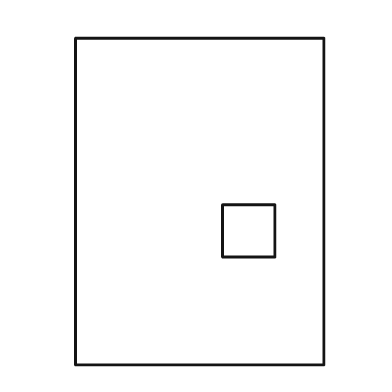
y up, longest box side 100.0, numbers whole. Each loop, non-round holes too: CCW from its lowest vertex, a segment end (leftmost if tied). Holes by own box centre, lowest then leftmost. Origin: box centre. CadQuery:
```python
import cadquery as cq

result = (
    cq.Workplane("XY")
    .moveTo(-38.0, -50.0)
    .lineTo(38.0, -50.0)
    .lineTo(38.0, 50.0)
    .lineTo(-38.0, 50.0)
    .close()
    .moveTo(7.0, -17.0)
    .lineTo(23.0, -17.0)
    .lineTo(23.0, -1.0)
    .lineTo(7.0, -1.0)
    .close()
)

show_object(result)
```